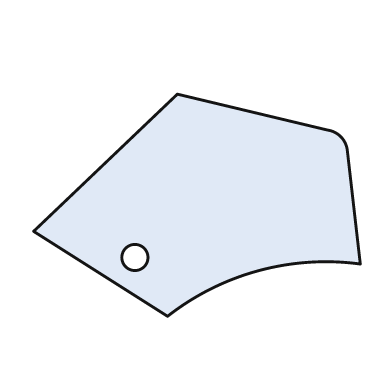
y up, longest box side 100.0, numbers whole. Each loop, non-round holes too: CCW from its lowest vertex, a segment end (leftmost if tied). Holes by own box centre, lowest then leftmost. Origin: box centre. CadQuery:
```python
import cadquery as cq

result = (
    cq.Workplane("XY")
    .moveTo(-9.0, -34.0)
    .threePointArc((19.0, -20.0), (50.0, -18.0))
    .lineTo(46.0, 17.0)
    .threePointArc((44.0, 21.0), (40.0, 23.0))
    .lineTo(-6.0, 34.0)
    .lineTo(-50.0, -8.0)
    .close()
    .moveTo(-19.0, -16.0)
    .circle(4.0)
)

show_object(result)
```